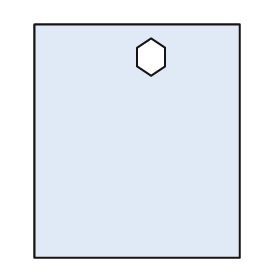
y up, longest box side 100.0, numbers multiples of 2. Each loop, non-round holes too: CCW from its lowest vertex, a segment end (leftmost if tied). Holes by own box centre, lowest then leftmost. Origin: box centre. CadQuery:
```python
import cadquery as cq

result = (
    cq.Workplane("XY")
    .moveTo(-44.0, -50.0)
    .lineTo(44.0, -50.0)
    .lineTo(44.0, 50.0)
    .lineTo(-44.0, 50.0)
    .close()
    .moveTo(6.0, 28.0)
    .lineTo(12.0, 32.0)
    .lineTo(12.0, 40.0)
    .lineTo(6.0, 44.0)
    .lineTo(0.0, 40.0)
    .lineTo(0.0, 32.0)
    .close()
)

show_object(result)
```